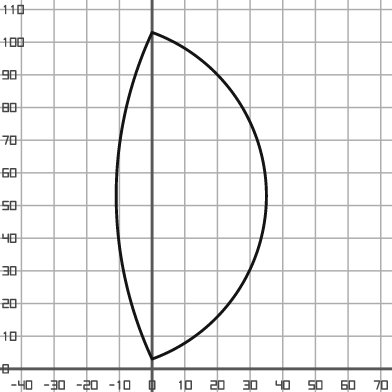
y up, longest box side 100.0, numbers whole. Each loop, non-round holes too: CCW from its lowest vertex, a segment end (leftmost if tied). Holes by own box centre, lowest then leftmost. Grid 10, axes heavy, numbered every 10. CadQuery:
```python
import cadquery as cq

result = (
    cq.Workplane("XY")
    .moveTo(0.0, 3.0)
    .threePointArc((35.0, 53.0), (0.0, 103.0))
    .threePointArc((-11.0, 53.0), (0.0, 3.0))
    .close()
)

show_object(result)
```